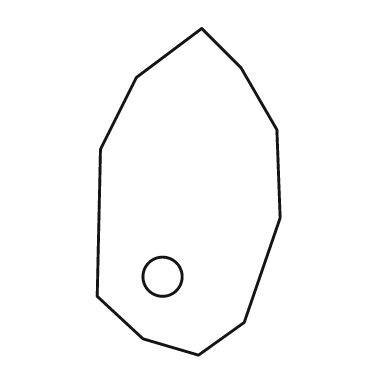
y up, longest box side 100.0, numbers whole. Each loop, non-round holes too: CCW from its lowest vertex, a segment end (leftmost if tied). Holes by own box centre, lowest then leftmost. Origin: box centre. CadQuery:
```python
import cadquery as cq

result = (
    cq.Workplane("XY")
    .moveTo(3.0, -50.0)
    .lineTo(17.0, -40.0)
    .lineTo(28.0, -8.0)
    .lineTo(27.0, 19.0)
    .lineTo(16.0, 38.0)
    .lineTo(4.0, 50.0)
    .lineTo(-16.0, 35.0)
    .lineTo(-27.0, 13.0)
    .lineTo(-28.0, -32.0)
    .lineTo(-14.0, -45.0)
    .close()
    .moveTo(-8.0, -26.0)
    .circle(6.0)
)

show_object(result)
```